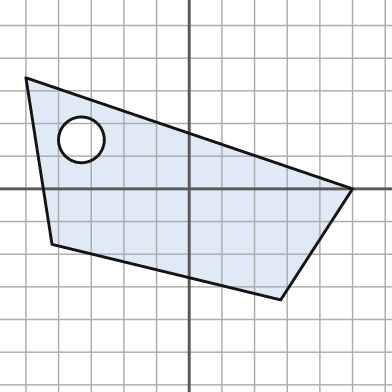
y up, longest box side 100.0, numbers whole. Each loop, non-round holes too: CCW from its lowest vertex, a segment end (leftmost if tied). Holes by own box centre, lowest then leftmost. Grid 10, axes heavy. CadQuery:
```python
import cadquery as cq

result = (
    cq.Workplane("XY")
    .moveTo(28.0, -34.0)
    .lineTo(50.0, 0.0)
    .lineTo(-50.0, 34.0)
    .lineTo(-42.0, -17.0)
    .close()
    .moveTo(-33.0, 15.0)
    .circle(7.0)
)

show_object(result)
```